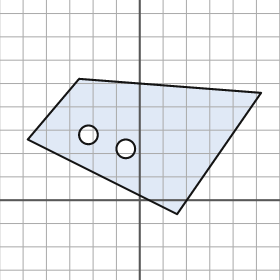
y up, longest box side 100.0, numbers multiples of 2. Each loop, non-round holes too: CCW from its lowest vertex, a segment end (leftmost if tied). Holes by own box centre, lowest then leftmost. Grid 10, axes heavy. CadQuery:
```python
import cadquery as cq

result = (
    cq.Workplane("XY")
    .moveTo(16.0, -6.0)
    .lineTo(52.0, 46.0)
    .lineTo(-26.0, 52.0)
    .lineTo(-48.0, 26.0)
    .close()
    .moveTo(-6.0, 22.0)
    .circle(4.0)
    .moveTo(-22.0, 28.0)
    .circle(4.0)
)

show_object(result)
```